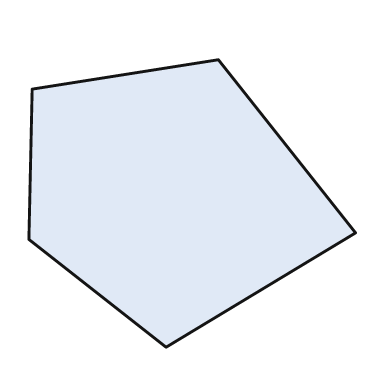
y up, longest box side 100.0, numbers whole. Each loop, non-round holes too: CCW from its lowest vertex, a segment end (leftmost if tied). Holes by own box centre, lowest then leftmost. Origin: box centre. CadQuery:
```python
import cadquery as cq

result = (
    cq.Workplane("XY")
    .moveTo(-8.0, -44.0)
    .lineTo(50.0, -9.0)
    .lineTo(8.0, 44.0)
    .lineTo(-49.0, 35.0)
    .lineTo(-50.0, -11.0)
    .close()
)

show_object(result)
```